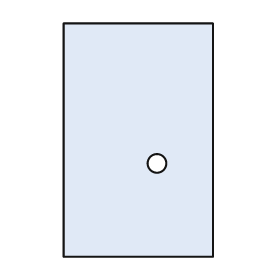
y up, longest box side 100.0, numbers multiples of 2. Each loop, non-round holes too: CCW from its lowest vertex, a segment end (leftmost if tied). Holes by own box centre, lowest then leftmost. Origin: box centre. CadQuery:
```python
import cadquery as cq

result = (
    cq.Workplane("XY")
    .moveTo(-32.0, -50.0)
    .lineTo(32.0, -50.0)
    .lineTo(32.0, 50.0)
    .lineTo(-32.0, 50.0)
    .close()
    .moveTo(8.0, -10.0)
    .circle(4.0)
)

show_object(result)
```